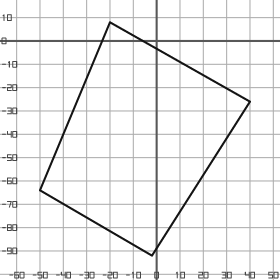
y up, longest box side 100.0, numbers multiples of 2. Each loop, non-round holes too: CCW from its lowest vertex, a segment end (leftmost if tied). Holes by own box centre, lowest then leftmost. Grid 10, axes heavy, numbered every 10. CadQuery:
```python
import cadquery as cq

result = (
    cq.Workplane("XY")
    .moveTo(-2.0, -92.0)
    .lineTo(40.0, -26.0)
    .lineTo(-20.0, 8.0)
    .lineTo(-50.0, -64.0)
    .close()
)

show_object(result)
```